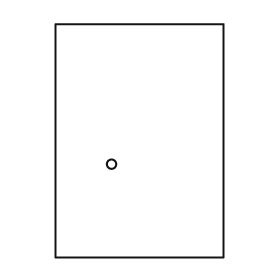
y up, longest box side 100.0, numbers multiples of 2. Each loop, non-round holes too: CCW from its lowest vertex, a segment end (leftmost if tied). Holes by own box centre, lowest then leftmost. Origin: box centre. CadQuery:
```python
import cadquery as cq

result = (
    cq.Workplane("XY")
    .moveTo(-36.0, -50.0)
    .lineTo(36.0, -50.0)
    .lineTo(36.0, 50.0)
    .lineTo(-36.0, 50.0)
    .close()
    .moveTo(-12.0, -10.0)
    .circle(2.0)
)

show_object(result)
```